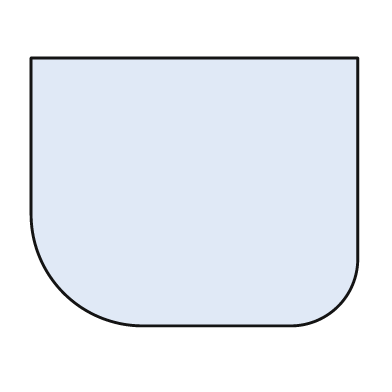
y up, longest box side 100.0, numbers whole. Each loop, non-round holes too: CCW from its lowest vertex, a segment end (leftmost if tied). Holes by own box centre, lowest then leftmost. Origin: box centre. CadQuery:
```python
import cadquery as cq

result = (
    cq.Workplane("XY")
    .moveTo(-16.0, -41.0)
    .lineTo(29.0, -41.0)
    .threePointArc((44.0, -35.0), (50.0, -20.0))
    .lineTo(50.0, 41.0)
    .lineTo(-50.0, 41.0)
    .lineTo(-50.0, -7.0)
    .threePointArc((-40.0, -31.0), (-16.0, -41.0))
    .close()
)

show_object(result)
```